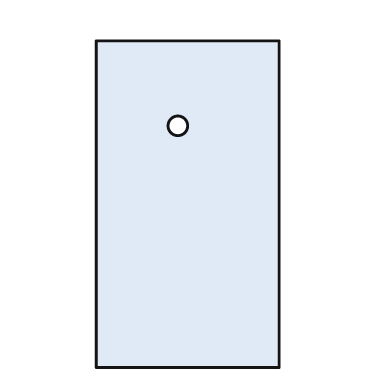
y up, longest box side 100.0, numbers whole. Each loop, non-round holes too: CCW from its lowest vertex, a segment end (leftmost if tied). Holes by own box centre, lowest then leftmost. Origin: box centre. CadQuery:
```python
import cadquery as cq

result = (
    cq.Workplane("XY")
    .moveTo(-28.0, -50.0)
    .lineTo(28.0, -50.0)
    .lineTo(28.0, 50.0)
    .lineTo(-28.0, 50.0)
    .close()
    .moveTo(-3.0, 24.0)
    .circle(3.0)
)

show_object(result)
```